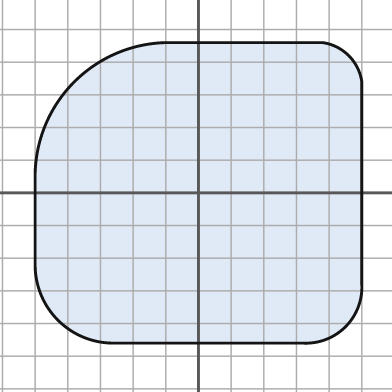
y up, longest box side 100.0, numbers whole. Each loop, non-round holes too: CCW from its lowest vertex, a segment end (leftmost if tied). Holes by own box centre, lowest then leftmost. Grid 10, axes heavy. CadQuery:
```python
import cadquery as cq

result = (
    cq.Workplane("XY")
    .moveTo(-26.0, -46.0)
    .lineTo(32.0, -46.0)
    .threePointArc((45.0, -41.0), (50.0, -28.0))
    .lineTo(50.0, 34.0)
    .threePointArc((46.0, 42.0), (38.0, 46.0))
    .lineTo(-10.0, 46.0)
    .threePointArc((-38.0, 34.0), (-50.0, 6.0))
    .lineTo(-50.0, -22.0)
    .threePointArc((-43.0, -39.0), (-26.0, -46.0))
    .close()
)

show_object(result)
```